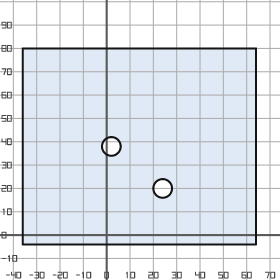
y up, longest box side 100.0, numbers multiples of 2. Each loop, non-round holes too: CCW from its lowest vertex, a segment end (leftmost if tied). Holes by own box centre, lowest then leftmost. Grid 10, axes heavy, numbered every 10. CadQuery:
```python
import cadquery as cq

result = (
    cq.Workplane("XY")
    .moveTo(-36.0, -4.0)
    .lineTo(64.0, -4.0)
    .lineTo(64.0, 80.0)
    .lineTo(-36.0, 80.0)
    .close()
    .moveTo(24.0, 20.0)
    .circle(4.0)
    .moveTo(2.0, 38.0)
    .circle(4.0)
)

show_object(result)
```